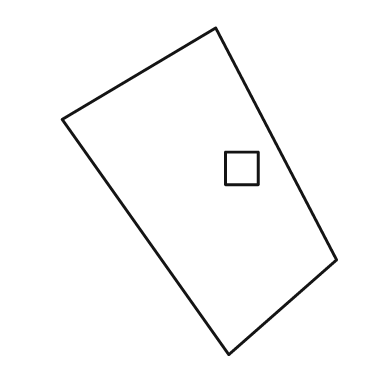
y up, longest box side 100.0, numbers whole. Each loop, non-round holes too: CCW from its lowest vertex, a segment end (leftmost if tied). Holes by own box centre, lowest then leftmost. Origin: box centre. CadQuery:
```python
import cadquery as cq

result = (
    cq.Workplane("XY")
    .moveTo(9.0, -50.0)
    .lineTo(42.0, -21.0)
    .lineTo(5.0, 50.0)
    .lineTo(-42.0, 22.0)
    .close()
    .moveTo(8.0, 2.0)
    .lineTo(18.0, 2.0)
    .lineTo(18.0, 12.0)
    .lineTo(8.0, 12.0)
    .close()
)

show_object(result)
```